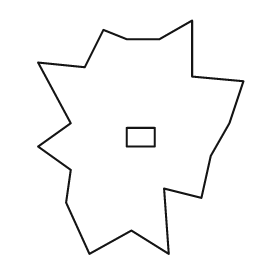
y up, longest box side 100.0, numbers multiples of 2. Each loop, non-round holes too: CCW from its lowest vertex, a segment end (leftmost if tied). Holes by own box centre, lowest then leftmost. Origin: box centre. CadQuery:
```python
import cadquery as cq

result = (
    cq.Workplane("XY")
    .moveTo(-22.0, -50.0)
    .lineTo(-4.0, -40.0)
    .lineTo(12.0, -50.0)
    .lineTo(10.0, -22.0)
    .lineTo(26.0, -26.0)
    .lineTo(30.0, -8.0)
    .lineTo(38.0, 6.0)
    .lineTo(44.0, 24.0)
    .lineTo(22.0, 26.0)
    .lineTo(22.0, 50.0)
    .lineTo(8.0, 42.0)
    .lineTo(-6.0, 42.0)
    .lineTo(-16.0, 46.0)
    .lineTo(-24.0, 30.0)
    .lineTo(-44.0, 32.0)
    .lineTo(-30.0, 6.0)
    .lineTo(-44.0, -4.0)
    .lineTo(-30.0, -14.0)
    .lineTo(-32.0, -28.0)
    .close()
    .moveTo(-6.0, -4.0)
    .lineTo(6.0, -4.0)
    .lineTo(6.0, 4.0)
    .lineTo(-6.0, 4.0)
    .close()
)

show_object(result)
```